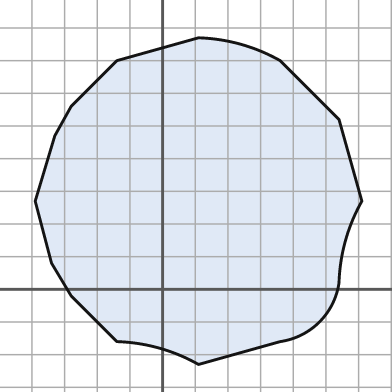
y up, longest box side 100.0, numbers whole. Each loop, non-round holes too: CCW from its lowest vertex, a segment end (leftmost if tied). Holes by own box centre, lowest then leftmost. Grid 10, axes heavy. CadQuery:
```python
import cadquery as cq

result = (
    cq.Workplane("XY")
    .moveTo(11.0, -23.0)
    .lineTo(36.0, -16.0)
    .threePointArc((48.0, -10.0), (54.0, 2.0))
    .threePointArc((56.0, 15.0), (61.0, 27.0))
    .lineTo(54.0, 52.0)
    .lineTo(36.0, 70.0)
    .threePointArc((24.0, 75.0), (11.0, 77.0))
    .lineTo(-14.0, 70.0)
    .lineTo(-28.0, 56.0)
    .lineTo(-33.0, 47.0)
    .lineTo(-39.0, 27.0)
    .lineTo(-34.0, 8.0)
    .lineTo(-28.0, -2.0)
    .lineTo(-14.0, -16.0)
    .threePointArc((-1.0, -18.0), (11.0, -23.0))
    .close()
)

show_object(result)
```